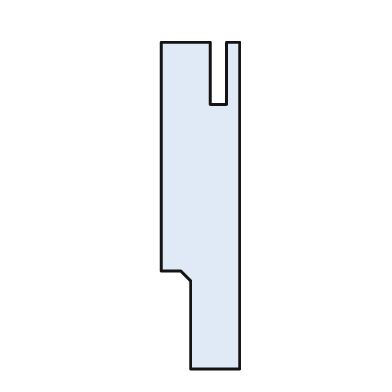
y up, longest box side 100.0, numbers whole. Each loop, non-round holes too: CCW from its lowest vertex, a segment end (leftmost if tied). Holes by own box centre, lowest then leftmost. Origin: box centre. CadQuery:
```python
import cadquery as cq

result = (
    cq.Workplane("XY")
    .moveTo(-3.0, -50.0)
    .lineTo(12.0, -50.0)
    .lineTo(12.0, 50.0)
    .lineTo(8.0, 50.0)
    .lineTo(8.0, 31.0)
    .lineTo(3.0, 31.0)
    .lineTo(3.0, 50.0)
    .lineTo(-12.0, 50.0)
    .lineTo(-12.0, -20.0)
    .lineTo(-6.0, -20.0)
    .lineTo(-3.0, -23.0)
    .close()
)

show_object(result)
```